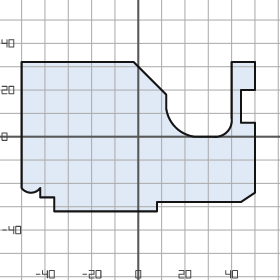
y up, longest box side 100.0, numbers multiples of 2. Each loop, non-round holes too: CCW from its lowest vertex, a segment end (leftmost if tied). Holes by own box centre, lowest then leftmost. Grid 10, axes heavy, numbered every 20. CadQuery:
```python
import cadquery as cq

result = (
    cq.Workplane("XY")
    .moveTo(-36.0, -32.0)
    .lineTo(8.0, -32.0)
    .lineTo(8.0, -28.0)
    .lineTo(44.0, -28.0)
    .lineTo(50.0, -24.0)
    .lineTo(50.0, 6.0)
    .lineTo(44.0, 6.0)
    .lineTo(44.0, 20.0)
    .lineTo(50.0, 20.0)
    .lineTo(50.0, 32.0)
    .lineTo(40.0, 32.0)
    .lineTo(40.0, 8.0)
    .threePointArc((38.0, 2.0), (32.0, 0.0))
    .lineTo(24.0, 0.0)
    .threePointArc((16.0, 4.0), (12.0, 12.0))
    .lineTo(12.0, 18.0)
    .lineTo(-2.0, 32.0)
    .lineTo(-50.0, 32.0)
    .lineTo(-50.0, -22.0)
    .threePointArc((-46.0, -24.0), (-42.0, -22.0))
    .lineTo(-42.0, -26.0)
    .lineTo(-36.0, -26.0)
    .close()
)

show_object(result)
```